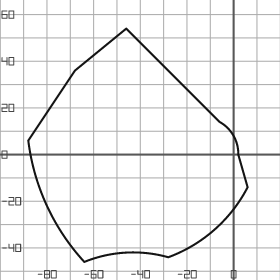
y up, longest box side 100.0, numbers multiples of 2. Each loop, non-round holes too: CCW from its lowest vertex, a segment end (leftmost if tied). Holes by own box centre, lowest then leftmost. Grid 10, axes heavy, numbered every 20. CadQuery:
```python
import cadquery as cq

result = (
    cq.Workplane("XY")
    .moveTo(-64.0, -46.0)
    .threePointArc((-46.0, -42.0), (-28.0, -44.0))
    .threePointArc((-8.0, -32.0), (6.0, -14.0))
    .lineTo(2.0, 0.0)
    .threePointArc((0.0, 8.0), (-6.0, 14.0))
    .lineTo(-46.0, 54.0)
    .lineTo(-68.0, 36.0)
    .lineTo(-88.0, 6.0)
    .threePointArc((-80.0, -22.0), (-64.0, -46.0))
    .close()
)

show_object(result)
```